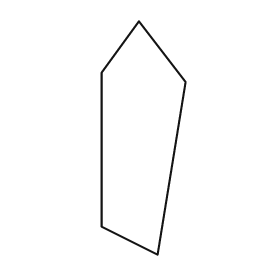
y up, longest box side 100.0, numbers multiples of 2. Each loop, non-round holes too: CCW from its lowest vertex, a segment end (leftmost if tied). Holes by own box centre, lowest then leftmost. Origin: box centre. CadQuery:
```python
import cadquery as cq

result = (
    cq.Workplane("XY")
    .moveTo(6.0, -50.0)
    .lineTo(18.0, 24.0)
    .lineTo(-2.0, 50.0)
    .lineTo(-18.0, 28.0)
    .lineTo(-18.0, -38.0)
    .close()
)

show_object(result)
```